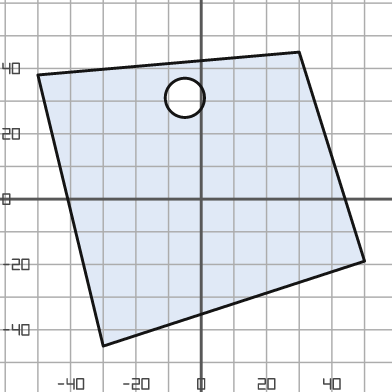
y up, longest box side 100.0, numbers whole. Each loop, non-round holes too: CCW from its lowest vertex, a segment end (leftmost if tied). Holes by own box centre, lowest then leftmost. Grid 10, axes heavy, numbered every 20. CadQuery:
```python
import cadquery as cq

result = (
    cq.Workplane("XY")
    .moveTo(-30.0, -45.0)
    .lineTo(50.0, -19.0)
    .lineTo(30.0, 45.0)
    .lineTo(-50.0, 38.0)
    .close()
    .moveTo(-5.0, 31.0)
    .circle(6.0)
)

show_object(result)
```